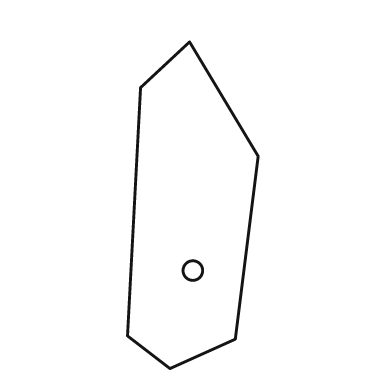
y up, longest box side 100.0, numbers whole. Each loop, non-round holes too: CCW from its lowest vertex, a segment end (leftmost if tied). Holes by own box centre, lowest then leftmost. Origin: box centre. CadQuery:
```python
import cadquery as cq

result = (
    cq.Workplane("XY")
    .moveTo(-7.0, -50.0)
    .lineTo(13.0, -41.0)
    .lineTo(20.0, 15.0)
    .lineTo(-1.0, 50.0)
    .lineTo(-16.0, 36.0)
    .lineTo(-20.0, -40.0)
    .close()
    .moveTo(0.0, -20.0)
    .circle(3.0)
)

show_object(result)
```